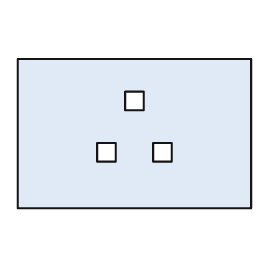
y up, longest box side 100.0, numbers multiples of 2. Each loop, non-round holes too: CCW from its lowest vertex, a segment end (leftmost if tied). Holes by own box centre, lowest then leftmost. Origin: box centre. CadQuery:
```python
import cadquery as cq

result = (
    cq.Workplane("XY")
    .moveTo(-50.0, -32.0)
    .lineTo(50.0, -32.0)
    .lineTo(50.0, 32.0)
    .lineTo(-50.0, 32.0)
    .close()
    .moveTo(-16.0, -12.0)
    .lineTo(-8.0, -12.0)
    .lineTo(-8.0, -4.0)
    .lineTo(-16.0, -4.0)
    .close()
    .moveTo(8.0, -12.0)
    .lineTo(16.0, -12.0)
    .lineTo(16.0, -4.0)
    .lineTo(8.0, -4.0)
    .close()
    .moveTo(-4.0, 10.0)
    .lineTo(4.0, 10.0)
    .lineTo(4.0, 18.0)
    .lineTo(-4.0, 18.0)
    .close()
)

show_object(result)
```